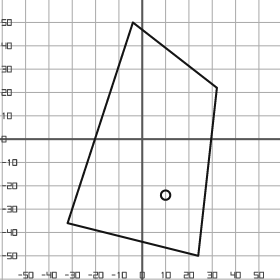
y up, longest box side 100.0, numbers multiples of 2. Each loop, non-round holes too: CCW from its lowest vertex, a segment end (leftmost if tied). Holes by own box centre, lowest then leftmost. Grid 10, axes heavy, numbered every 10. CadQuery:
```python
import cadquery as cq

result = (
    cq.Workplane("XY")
    .moveTo(24.0, -50.0)
    .lineTo(32.0, 22.0)
    .lineTo(-4.0, 50.0)
    .lineTo(-32.0, -36.0)
    .close()
    .moveTo(10.0, -24.0)
    .circle(2.0)
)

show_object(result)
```